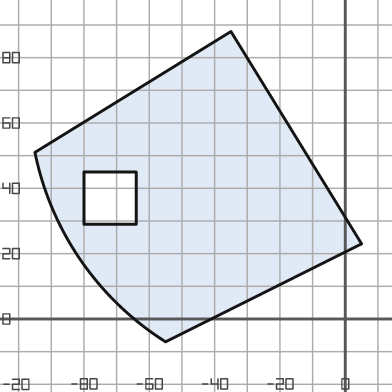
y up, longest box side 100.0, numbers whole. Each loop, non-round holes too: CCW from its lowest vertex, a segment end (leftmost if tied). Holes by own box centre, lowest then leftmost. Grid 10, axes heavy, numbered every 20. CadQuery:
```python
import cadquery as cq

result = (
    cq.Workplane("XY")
    .moveTo(-55.0, -7.0)
    .lineTo(5.0, 23.0)
    .lineTo(-35.0, 88.0)
    .lineTo(-95.0, 51.0)
    .threePointArc((-81.0, 18.0), (-55.0, -7.0))
    .close()
    .moveTo(-80.0, 29.0)
    .lineTo(-64.0, 29.0)
    .lineTo(-64.0, 45.0)
    .lineTo(-80.0, 45.0)
    .close()
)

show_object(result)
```